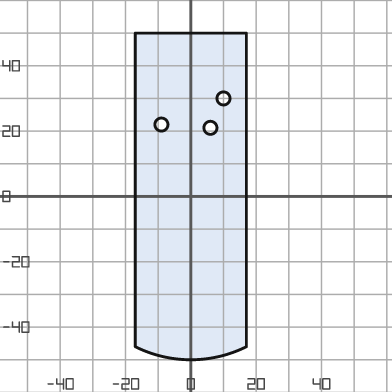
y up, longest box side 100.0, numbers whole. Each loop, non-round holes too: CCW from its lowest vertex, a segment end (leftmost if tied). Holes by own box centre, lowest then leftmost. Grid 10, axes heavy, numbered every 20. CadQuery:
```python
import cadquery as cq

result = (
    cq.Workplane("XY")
    .moveTo(-17.0, -46.0)
    .threePointArc((0.0, -50.0), (17.0, -46.0))
    .lineTo(17.0, 50.0)
    .lineTo(-17.0, 50.0)
    .close()
    .moveTo(6.0, 21.0)
    .circle(2.0)
    .moveTo(-9.0, 22.0)
    .circle(2.0)
    .moveTo(10.0, 30.0)
    .circle(2.0)
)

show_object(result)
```